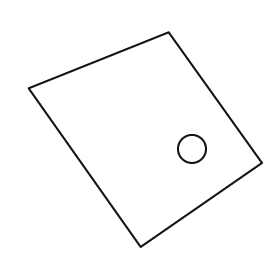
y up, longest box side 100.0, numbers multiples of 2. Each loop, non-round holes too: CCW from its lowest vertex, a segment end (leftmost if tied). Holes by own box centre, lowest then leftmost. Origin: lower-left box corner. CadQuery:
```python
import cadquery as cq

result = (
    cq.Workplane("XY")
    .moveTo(48.0, 0.0)
    .lineTo(100.0, 36.0)
    .lineTo(60.0, 92.0)
    .lineTo(0.0, 68.0)
    .close()
    .moveTo(70.0, 42.0)
    .circle(6.0)
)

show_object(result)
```